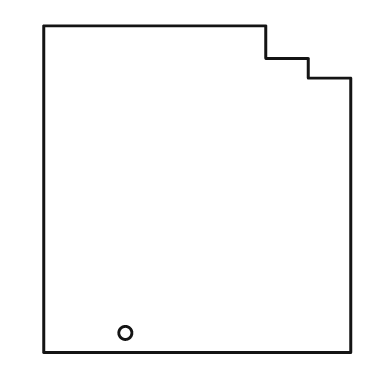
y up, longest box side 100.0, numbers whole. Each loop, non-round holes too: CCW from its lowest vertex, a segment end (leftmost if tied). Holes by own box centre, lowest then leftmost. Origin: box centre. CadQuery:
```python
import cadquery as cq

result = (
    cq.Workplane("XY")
    .moveTo(-47.0, -50.0)
    .lineTo(47.0, -50.0)
    .lineTo(47.0, 34.0)
    .lineTo(34.0, 34.0)
    .lineTo(34.0, 40.0)
    .lineTo(21.0, 40.0)
    .lineTo(21.0, 50.0)
    .lineTo(-47.0, 50.0)
    .close()
    .moveTo(-22.0, -44.0)
    .circle(2.0)
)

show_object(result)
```